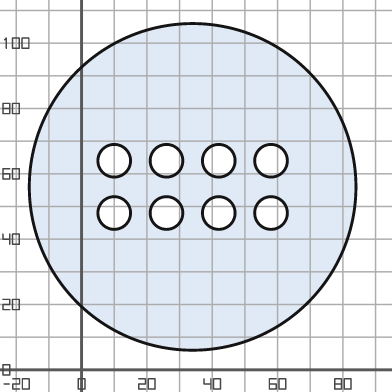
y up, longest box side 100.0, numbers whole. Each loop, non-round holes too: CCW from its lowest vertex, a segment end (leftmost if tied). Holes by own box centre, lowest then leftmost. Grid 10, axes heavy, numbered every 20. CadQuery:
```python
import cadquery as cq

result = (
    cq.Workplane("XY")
    .moveTo(34.0, 56.0)
    .circle(50.0)
    .moveTo(10.0, 48.0)
    .circle(5.0)
    .moveTo(26.0, 48.0)
    .circle(5.0)
    .moveTo(42.0, 48.0)
    .circle(5.0)
    .moveTo(58.0, 48.0)
    .circle(5.0)
    .moveTo(10.0, 64.0)
    .circle(5.0)
    .moveTo(26.0, 64.0)
    .circle(5.0)
    .moveTo(42.0, 64.0)
    .circle(5.0)
    .moveTo(58.0, 64.0)
    .circle(5.0)
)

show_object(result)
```